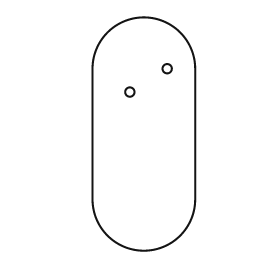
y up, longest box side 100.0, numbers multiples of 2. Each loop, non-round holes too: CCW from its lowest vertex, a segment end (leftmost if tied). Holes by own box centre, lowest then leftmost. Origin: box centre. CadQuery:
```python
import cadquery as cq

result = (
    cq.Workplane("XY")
    .moveTo(-22.0, -28.0)
    .threePointArc((0.0, -50.0), (22.0, -28.0))
    .lineTo(22.0, 28.0)
    .threePointArc((0.0, 50.0), (-22.0, 28.0))
    .close()
    .moveTo(-6.0, 18.0)
    .circle(2.0)
    .moveTo(10.0, 28.0)
    .circle(2.0)
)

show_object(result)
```